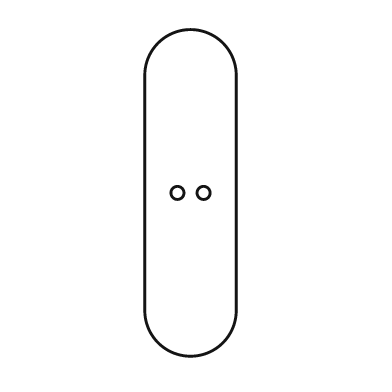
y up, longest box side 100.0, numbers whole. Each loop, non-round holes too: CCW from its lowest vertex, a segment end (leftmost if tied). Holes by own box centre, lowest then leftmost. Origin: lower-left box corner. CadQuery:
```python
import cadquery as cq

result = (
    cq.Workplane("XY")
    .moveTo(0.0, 14.0)
    .threePointArc((14.0, 0.0), (28.0, 14.0))
    .lineTo(28.0, 86.0)
    .threePointArc((14.0, 100.0), (0.0, 86.0))
    .close()
    .moveTo(10.0, 50.0)
    .circle(2.0)
    .moveTo(18.0, 50.0)
    .circle(2.0)
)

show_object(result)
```